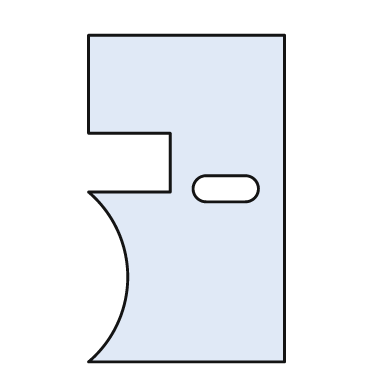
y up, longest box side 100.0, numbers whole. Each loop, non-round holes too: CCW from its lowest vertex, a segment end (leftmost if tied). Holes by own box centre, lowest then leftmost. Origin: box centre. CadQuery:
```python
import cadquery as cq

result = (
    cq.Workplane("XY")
    .moveTo(-30.0, -50.0)
    .lineTo(30.0, -50.0)
    .lineTo(30.0, 50.0)
    .lineTo(-30.0, 50.0)
    .lineTo(-30.0, 20.0)
    .lineTo(-5.0, 20.0)
    .lineTo(-5.0, 2.0)
    .lineTo(-30.0, 2.0)
    .threePointArc((-18.0, -24.0), (-30.0, -50.0))
    .close()
    .moveTo(6.0, -1.0)
    .lineTo(18.0, -1.0)
    .threePointArc((22.0, 3.0), (18.0, 7.0))
    .lineTo(6.0, 7.0)
    .threePointArc((2.0, 3.0), (6.0, -1.0))
    .close()
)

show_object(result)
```